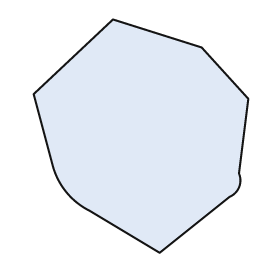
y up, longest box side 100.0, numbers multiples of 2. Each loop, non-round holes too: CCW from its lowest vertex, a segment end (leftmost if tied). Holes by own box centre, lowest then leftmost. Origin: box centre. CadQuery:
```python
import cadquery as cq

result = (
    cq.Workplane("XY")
    .moveTo(8.0, -50.0)
    .lineTo(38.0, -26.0)
    .threePointArc((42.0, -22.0), (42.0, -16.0))
    .lineTo(46.0, 16.0)
    .lineTo(26.0, 38.0)
    .lineTo(-12.0, 50.0)
    .lineTo(-46.0, 18.0)
    .lineTo(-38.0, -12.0)
    .threePointArc((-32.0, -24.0), (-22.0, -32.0))
    .close()
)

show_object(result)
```